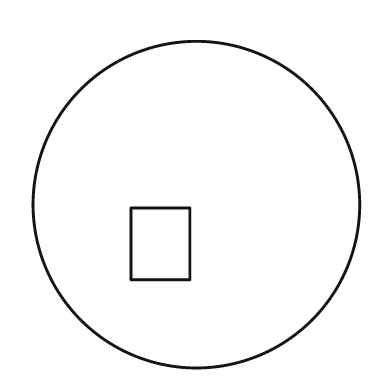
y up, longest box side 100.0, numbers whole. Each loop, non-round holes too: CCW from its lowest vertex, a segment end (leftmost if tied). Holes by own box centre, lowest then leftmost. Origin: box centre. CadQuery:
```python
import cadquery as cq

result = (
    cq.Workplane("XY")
    .moveTo(0.0, 0.0)
    .circle(50.0)
    .moveTo(-20.0, -23.0)
    .lineTo(-2.0, -23.0)
    .lineTo(-2.0, -1.0)
    .lineTo(-20.0, -1.0)
    .close()
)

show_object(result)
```